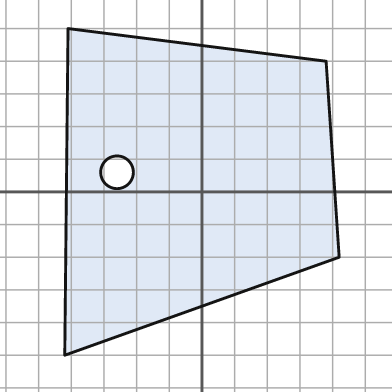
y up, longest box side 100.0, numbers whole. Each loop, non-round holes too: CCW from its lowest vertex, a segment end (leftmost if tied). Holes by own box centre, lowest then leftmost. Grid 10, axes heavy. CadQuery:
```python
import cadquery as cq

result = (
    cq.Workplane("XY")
    .moveTo(-42.0, -50.0)
    .lineTo(42.0, -20.0)
    .lineTo(38.0, 40.0)
    .lineTo(-41.0, 50.0)
    .close()
    .moveTo(-26.0, 6.0)
    .circle(5.0)
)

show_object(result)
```